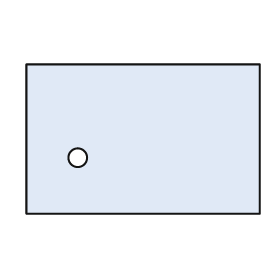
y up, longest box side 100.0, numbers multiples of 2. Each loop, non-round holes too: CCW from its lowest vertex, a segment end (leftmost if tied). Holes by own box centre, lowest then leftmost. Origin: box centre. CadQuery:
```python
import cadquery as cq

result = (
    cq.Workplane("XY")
    .moveTo(-50.0, -32.0)
    .lineTo(50.0, -32.0)
    .lineTo(50.0, 32.0)
    .lineTo(-50.0, 32.0)
    .close()
    .moveTo(-28.0, -8.0)
    .circle(4.0)
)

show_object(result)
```